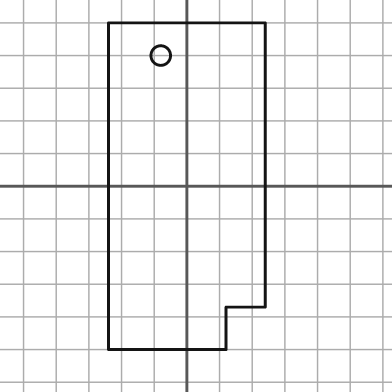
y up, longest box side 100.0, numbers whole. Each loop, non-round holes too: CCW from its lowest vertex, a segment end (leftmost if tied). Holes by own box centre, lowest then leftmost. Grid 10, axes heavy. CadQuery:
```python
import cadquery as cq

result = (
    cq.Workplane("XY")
    .moveTo(-24.0, -50.0)
    .lineTo(12.0, -50.0)
    .lineTo(12.0, -37.0)
    .lineTo(24.0, -37.0)
    .lineTo(24.0, 50.0)
    .lineTo(-24.0, 50.0)
    .close()
    .moveTo(-8.0, 40.0)
    .circle(3.0)
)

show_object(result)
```